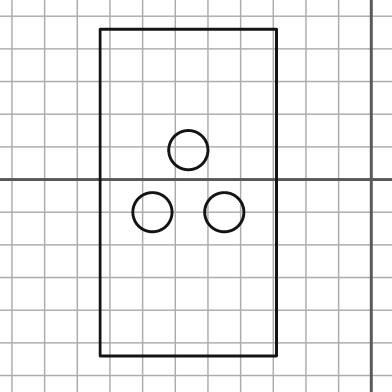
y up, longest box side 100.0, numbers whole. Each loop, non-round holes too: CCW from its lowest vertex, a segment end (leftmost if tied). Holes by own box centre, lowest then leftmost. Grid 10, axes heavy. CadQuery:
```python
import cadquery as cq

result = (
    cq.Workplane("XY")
    .moveTo(-83.0, -54.0)
    .lineTo(-29.0, -54.0)
    .lineTo(-29.0, 46.0)
    .lineTo(-83.0, 46.0)
    .close()
    .moveTo(-67.0, -10.0)
    .circle(6.0)
    .moveTo(-45.0, -10.0)
    .circle(6.0)
    .moveTo(-56.0, 9.0)
    .circle(6.0)
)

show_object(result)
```